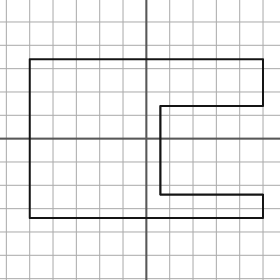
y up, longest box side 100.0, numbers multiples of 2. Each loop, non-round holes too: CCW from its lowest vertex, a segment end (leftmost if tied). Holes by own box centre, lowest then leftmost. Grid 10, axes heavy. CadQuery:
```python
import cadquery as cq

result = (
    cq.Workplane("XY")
    .moveTo(-50.0, -34.0)
    .lineTo(50.0, -34.0)
    .lineTo(50.0, -24.0)
    .lineTo(6.0, -24.0)
    .lineTo(6.0, 14.0)
    .lineTo(50.0, 14.0)
    .lineTo(50.0, 34.0)
    .lineTo(-50.0, 34.0)
    .close()
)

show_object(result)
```